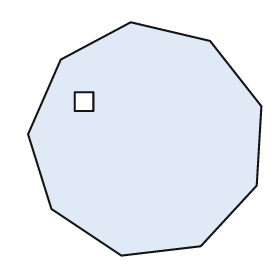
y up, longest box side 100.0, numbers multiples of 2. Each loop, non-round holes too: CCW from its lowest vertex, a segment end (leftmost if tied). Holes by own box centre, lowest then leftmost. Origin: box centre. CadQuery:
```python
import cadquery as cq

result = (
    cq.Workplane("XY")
    .moveTo(-10.0, -50.0)
    .lineTo(24.0, -46.0)
    .lineTo(48.0, -20.0)
    .lineTo(50.0, 14.0)
    .lineTo(28.0, 42.0)
    .lineTo(-6.0, 50.0)
    .lineTo(-36.0, 34.0)
    .lineTo(-50.0, 2.0)
    .lineTo(-40.0, -30.0)
    .close()
    .moveTo(-30.0, 12.0)
    .lineTo(-22.0, 12.0)
    .lineTo(-22.0, 20.0)
    .lineTo(-30.0, 20.0)
    .close()
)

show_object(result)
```